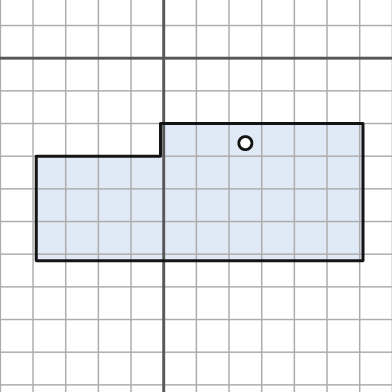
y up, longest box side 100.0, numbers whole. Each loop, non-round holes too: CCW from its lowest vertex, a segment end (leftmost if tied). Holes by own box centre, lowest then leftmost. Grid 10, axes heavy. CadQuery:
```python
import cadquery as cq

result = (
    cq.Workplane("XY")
    .moveTo(-39.0, -62.0)
    .lineTo(61.0, -62.0)
    .lineTo(61.0, -20.0)
    .lineTo(-1.0, -20.0)
    .lineTo(-1.0, -30.0)
    .lineTo(-39.0, -30.0)
    .close()
    .moveTo(25.0, -26.0)
    .circle(2.0)
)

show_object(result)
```